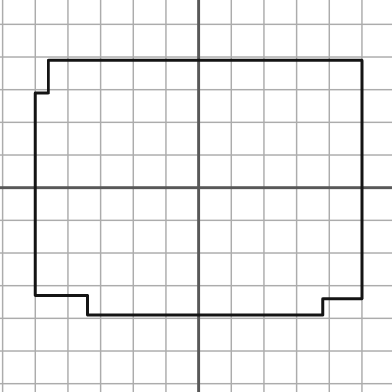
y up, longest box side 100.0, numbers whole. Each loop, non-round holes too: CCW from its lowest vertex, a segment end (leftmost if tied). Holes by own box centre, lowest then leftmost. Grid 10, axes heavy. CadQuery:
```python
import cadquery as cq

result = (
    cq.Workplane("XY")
    .moveTo(-34.0, -39.0)
    .lineTo(38.0, -39.0)
    .lineTo(38.0, -34.0)
    .lineTo(50.0, -34.0)
    .lineTo(50.0, 39.0)
    .lineTo(-46.0, 39.0)
    .lineTo(-46.0, 29.0)
    .lineTo(-50.0, 29.0)
    .lineTo(-50.0, -33.0)
    .lineTo(-34.0, -33.0)
    .close()
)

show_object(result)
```